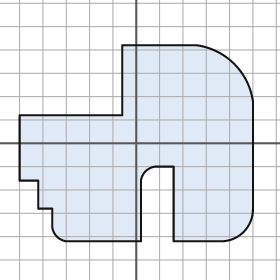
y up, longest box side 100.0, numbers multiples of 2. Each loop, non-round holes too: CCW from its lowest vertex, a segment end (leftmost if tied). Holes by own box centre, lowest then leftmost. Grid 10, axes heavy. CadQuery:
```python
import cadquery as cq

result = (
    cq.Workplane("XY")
    .moveTo(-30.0, -42.0)
    .lineTo(2.0, -42.0)
    .lineTo(2.0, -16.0)
    .threePointArc((4.0, -12.0), (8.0, -10.0))
    .lineTo(16.0, -10.0)
    .lineTo(16.0, -42.0)
    .lineTo(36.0, -42.0)
    .threePointArc((46.0, -38.0), (50.0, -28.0))
    .lineTo(50.0, 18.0)
    .threePointArc((42.0, 34.0), (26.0, 42.0))
    .lineTo(-6.0, 42.0)
    .lineTo(-6.0, 12.0)
    .lineTo(-50.0, 12.0)
    .lineTo(-50.0, -16.0)
    .lineTo(-42.0, -16.0)
    .lineTo(-42.0, -28.0)
    .lineTo(-36.0, -28.0)
    .lineTo(-36.0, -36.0)
    .threePointArc((-34.0, -40.0), (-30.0, -42.0))
    .close()
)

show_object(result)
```